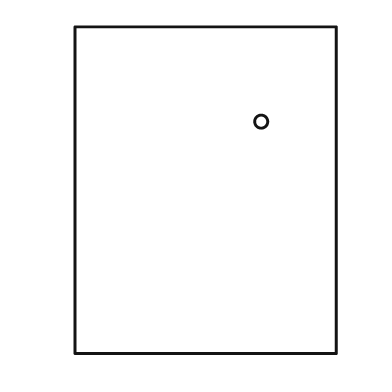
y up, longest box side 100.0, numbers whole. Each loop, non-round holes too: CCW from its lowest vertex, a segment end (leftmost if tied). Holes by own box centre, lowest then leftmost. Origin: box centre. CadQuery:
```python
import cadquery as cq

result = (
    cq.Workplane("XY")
    .moveTo(-40.0, -50.0)
    .lineTo(40.0, -50.0)
    .lineTo(40.0, 50.0)
    .lineTo(-40.0, 50.0)
    .close()
    .moveTo(17.0, 21.0)
    .circle(2.0)
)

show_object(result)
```